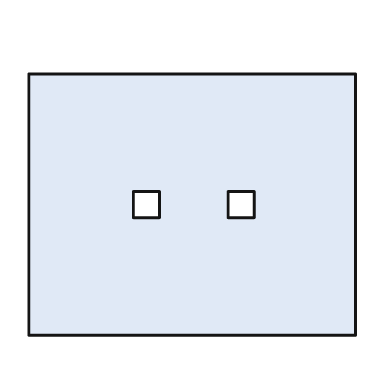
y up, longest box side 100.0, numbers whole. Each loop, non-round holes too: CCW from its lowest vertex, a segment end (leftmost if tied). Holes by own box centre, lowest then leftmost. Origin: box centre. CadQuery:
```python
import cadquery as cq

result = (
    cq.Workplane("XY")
    .moveTo(-50.0, -40.0)
    .lineTo(50.0, -40.0)
    .lineTo(50.0, 40.0)
    .lineTo(-50.0, 40.0)
    .close()
    .moveTo(-18.0, -4.0)
    .lineTo(-10.0, -4.0)
    .lineTo(-10.0, 4.0)
    .lineTo(-18.0, 4.0)
    .close()
    .moveTo(11.0, -4.0)
    .lineTo(19.0, -4.0)
    .lineTo(19.0, 4.0)
    .lineTo(11.0, 4.0)
    .close()
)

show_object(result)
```